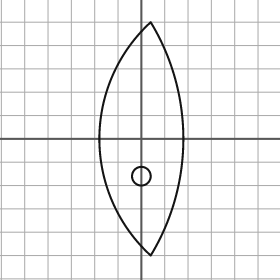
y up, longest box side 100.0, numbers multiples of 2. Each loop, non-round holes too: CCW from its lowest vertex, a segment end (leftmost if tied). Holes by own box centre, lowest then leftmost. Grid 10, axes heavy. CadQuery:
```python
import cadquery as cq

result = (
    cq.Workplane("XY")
    .moveTo(4.0, -50.0)
    .threePointArc((18.0, 0.0), (4.0, 50.0))
    .threePointArc((-18.0, 0.0), (4.0, -50.0))
    .close()
    .moveTo(0.0, -16.0)
    .circle(4.0)
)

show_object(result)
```